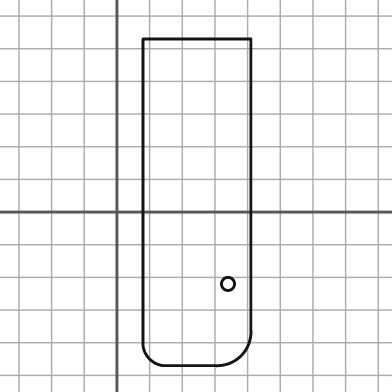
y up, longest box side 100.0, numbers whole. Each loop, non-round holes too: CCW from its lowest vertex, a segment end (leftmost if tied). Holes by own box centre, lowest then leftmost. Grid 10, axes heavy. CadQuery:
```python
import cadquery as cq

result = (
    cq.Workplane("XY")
    .moveTo(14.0, -47.0)
    .lineTo(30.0, -47.0)
    .threePointArc((38.0, -44.0), (41.0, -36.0))
    .lineTo(41.0, 53.0)
    .lineTo(8.0, 53.0)
    .lineTo(8.0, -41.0)
    .threePointArc((10.0, -45.0), (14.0, -47.0))
    .close()
    .moveTo(34.0, -22.0)
    .circle(2.0)
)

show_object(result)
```